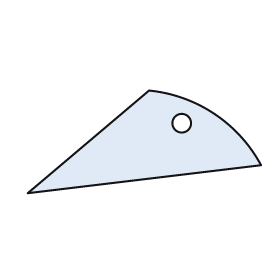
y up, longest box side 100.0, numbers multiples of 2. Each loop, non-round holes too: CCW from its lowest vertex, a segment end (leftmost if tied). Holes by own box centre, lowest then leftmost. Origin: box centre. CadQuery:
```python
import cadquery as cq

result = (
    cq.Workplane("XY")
    .moveTo(-50.0, -22.0)
    .lineTo(50.0, -10.0)
    .threePointArc((30.0, 12.0), (2.0, 22.0))
    .close()
    .moveTo(16.0, 8.0)
    .circle(4.0)
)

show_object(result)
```